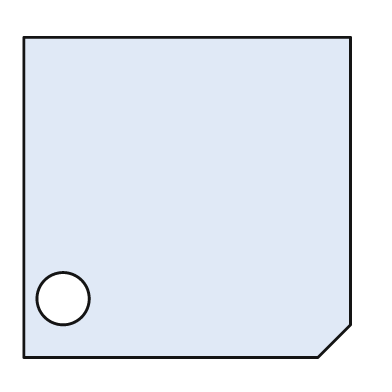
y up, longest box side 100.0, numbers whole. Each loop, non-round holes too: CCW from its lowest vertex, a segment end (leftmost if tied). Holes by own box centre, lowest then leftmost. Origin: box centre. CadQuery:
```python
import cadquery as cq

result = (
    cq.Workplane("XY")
    .moveTo(-50.0, -49.0)
    .lineTo(40.0, -49.0)
    .lineTo(50.0, -39.0)
    .lineTo(50.0, 49.0)
    .lineTo(-50.0, 49.0)
    .close()
    .moveTo(-38.0, -31.0)
    .circle(8.0)
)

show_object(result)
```